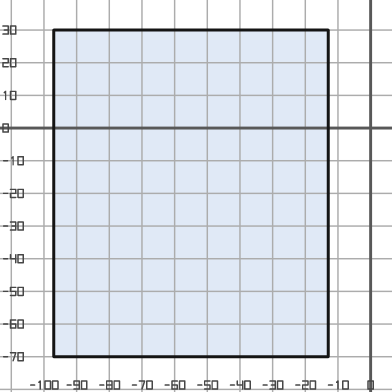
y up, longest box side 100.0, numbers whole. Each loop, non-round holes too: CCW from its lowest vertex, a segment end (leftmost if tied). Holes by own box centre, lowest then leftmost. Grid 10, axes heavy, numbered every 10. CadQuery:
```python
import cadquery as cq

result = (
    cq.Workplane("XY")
    .moveTo(-97.0, -70.0)
    .lineTo(-13.0, -70.0)
    .lineTo(-13.0, 30.0)
    .lineTo(-97.0, 30.0)
    .close()
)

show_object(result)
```